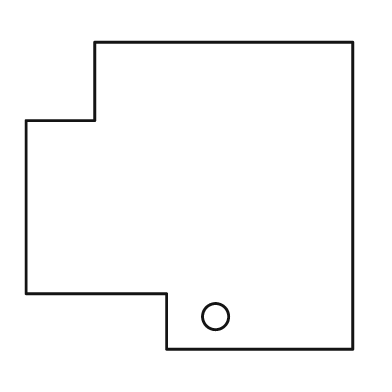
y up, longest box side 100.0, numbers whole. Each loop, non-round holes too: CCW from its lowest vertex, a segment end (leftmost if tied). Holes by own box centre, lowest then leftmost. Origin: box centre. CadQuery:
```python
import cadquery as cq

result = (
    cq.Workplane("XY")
    .moveTo(-7.0, -47.0)
    .lineTo(50.0, -47.0)
    .lineTo(50.0, 47.0)
    .lineTo(-29.0, 47.0)
    .lineTo(-29.0, 23.0)
    .lineTo(-50.0, 23.0)
    .lineTo(-50.0, -30.0)
    .lineTo(-7.0, -30.0)
    .close()
    .moveTo(8.0, -37.0)
    .circle(4.0)
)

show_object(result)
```